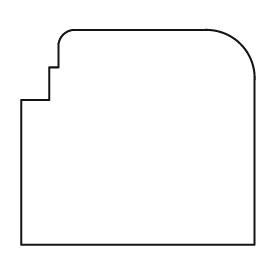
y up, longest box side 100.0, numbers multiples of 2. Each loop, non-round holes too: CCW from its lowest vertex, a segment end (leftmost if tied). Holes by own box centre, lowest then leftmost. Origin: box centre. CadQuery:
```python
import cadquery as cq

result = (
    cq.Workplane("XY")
    .moveTo(-50.0, -46.0)
    .lineTo(50.0, -46.0)
    .lineTo(50.0, 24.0)
    .threePointArc((44.0, 40.0), (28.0, 46.0))
    .lineTo(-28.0, 46.0)
    .threePointArc((-32.0, 44.0), (-34.0, 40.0))
    .lineTo(-34.0, 30.0)
    .lineTo(-38.0, 30.0)
    .lineTo(-38.0, 16.0)
    .lineTo(-50.0, 16.0)
    .close()
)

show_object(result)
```